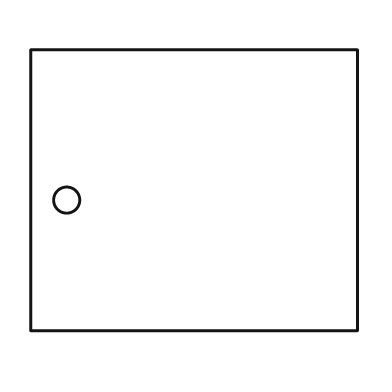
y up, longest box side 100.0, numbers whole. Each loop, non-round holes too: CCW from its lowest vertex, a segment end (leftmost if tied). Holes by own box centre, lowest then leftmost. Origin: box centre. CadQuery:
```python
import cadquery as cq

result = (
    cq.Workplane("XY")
    .moveTo(-50.0, -43.0)
    .lineTo(50.0, -43.0)
    .lineTo(50.0, 43.0)
    .lineTo(-50.0, 43.0)
    .close()
    .moveTo(-39.0, -3.0)
    .circle(4.0)
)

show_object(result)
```